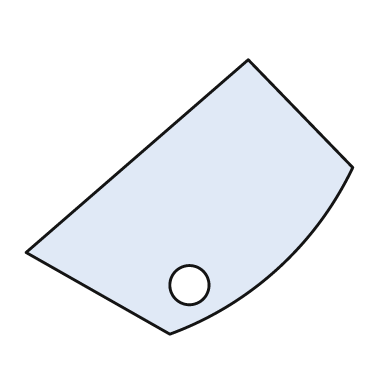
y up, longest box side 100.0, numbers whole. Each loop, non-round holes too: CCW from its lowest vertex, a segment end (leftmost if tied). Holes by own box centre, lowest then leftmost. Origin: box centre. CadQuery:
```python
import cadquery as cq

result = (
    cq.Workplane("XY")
    .moveTo(-6.0, -42.0)
    .threePointArc((27.0, -22.0), (50.0, 9.0))
    .lineTo(18.0, 42.0)
    .lineTo(-50.0, -17.0)
    .close()
    .moveTo(0.0, -27.0)
    .circle(6.0)
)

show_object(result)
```